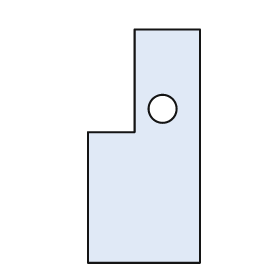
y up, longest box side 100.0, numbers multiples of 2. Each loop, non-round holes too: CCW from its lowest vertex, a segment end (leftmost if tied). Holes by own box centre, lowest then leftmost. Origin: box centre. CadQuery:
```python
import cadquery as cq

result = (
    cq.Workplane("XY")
    .moveTo(-24.0, -50.0)
    .lineTo(24.0, -50.0)
    .lineTo(24.0, 50.0)
    .lineTo(-4.0, 50.0)
    .lineTo(-4.0, 6.0)
    .lineTo(-24.0, 6.0)
    .close()
    .moveTo(8.0, 16.0)
    .circle(6.0)
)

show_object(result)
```